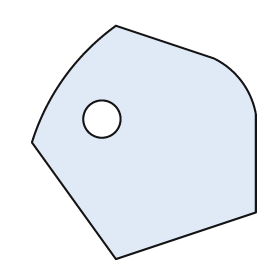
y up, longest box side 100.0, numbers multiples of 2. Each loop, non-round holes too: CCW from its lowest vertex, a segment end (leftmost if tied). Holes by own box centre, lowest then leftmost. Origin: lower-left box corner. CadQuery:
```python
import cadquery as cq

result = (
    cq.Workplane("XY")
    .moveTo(36.0, 0.0)
    .lineTo(96.0, 20.0)
    .lineTo(96.0, 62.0)
    .threePointArc((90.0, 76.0), (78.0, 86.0))
    .lineTo(36.0, 100.0)
    .threePointArc((14.0, 78.0), (0.0, 50.0))
    .close()
    .moveTo(30.0, 60.0)
    .circle(8.0)
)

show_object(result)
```